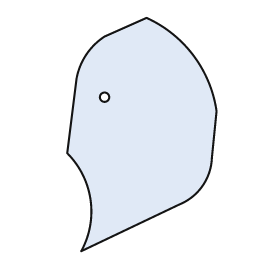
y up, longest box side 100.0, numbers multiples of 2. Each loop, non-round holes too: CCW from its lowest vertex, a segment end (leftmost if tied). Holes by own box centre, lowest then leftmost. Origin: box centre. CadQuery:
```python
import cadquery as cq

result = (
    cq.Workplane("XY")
    .moveTo(-26.0, -50.0)
    .lineTo(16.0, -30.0)
    .threePointArc((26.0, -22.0), (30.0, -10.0))
    .lineTo(32.0, 10.0)
    .threePointArc((22.0, 34.0), (2.0, 50.0))
    .lineTo(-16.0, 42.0)
    .threePointArc((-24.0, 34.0), (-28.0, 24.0))
    .lineTo(-32.0, -8.0)
    .threePointArc((-22.0, -28.0), (-26.0, -50.0))
    .close()
    .moveTo(-16.0, 16.0)
    .circle(2.0)
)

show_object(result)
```